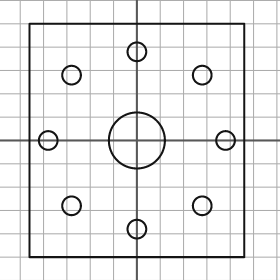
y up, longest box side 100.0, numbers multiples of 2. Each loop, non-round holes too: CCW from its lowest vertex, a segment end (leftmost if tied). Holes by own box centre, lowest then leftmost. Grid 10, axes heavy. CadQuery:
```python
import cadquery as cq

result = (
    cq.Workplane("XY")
    .moveTo(-46.0, -50.0)
    .lineTo(46.0, -50.0)
    .lineTo(46.0, 50.0)
    .lineTo(-46.0, 50.0)
    .close()
    .moveTo(0.0, -38.0)
    .circle(4.0)
    .moveTo(-28.0, -28.0)
    .circle(4.0)
    .moveTo(28.0, -28.0)
    .circle(4.0)
    .moveTo(-38.0, 0.0)
    .circle(4.0)
    .moveTo(0.0, 0.0)
    .circle(12.0)
    .moveTo(38.0, 0.0)
    .circle(4.0)
    .moveTo(-28.0, 28.0)
    .circle(4.0)
    .moveTo(28.0, 28.0)
    .circle(4.0)
    .moveTo(0.0, 38.0)
    .circle(4.0)
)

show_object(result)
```